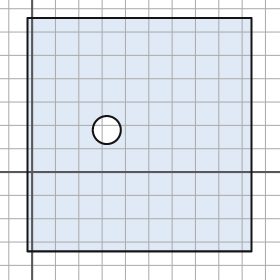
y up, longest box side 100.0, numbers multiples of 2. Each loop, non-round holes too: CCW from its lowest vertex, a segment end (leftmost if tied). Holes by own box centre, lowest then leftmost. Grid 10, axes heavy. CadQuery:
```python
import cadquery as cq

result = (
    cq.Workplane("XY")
    .moveTo(-2.0, -34.0)
    .lineTo(94.0, -34.0)
    .lineTo(94.0, 66.0)
    .lineTo(-2.0, 66.0)
    .close()
    .moveTo(32.0, 18.0)
    .circle(6.0)
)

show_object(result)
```